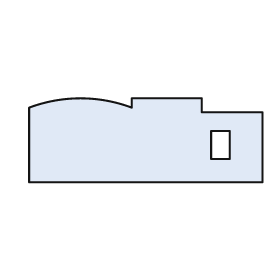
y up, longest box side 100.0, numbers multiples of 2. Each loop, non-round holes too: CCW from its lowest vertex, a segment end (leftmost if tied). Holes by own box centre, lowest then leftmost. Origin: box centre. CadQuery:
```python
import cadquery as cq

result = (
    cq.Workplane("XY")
    .moveTo(-50.0, -18.0)
    .lineTo(50.0, -18.0)
    .lineTo(50.0, 12.0)
    .lineTo(24.0, 12.0)
    .lineTo(24.0, 18.0)
    .lineTo(-6.0, 18.0)
    .lineTo(-6.0, 14.0)
    .threePointArc((-28.0, 18.0), (-50.0, 14.0))
    .close()
    .moveTo(28.0, -8.0)
    .lineTo(36.0, -8.0)
    .lineTo(36.0, 4.0)
    .lineTo(28.0, 4.0)
    .close()
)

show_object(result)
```